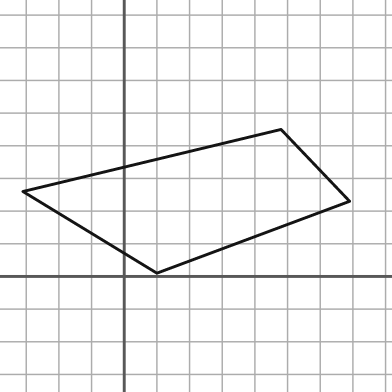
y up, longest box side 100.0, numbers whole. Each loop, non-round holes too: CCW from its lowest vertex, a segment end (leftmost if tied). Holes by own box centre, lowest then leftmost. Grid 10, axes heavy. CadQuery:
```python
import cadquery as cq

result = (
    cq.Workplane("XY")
    .moveTo(10.0, 1.0)
    .lineTo(69.0, 23.0)
    .lineTo(48.0, 45.0)
    .lineTo(-31.0, 26.0)
    .close()
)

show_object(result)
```